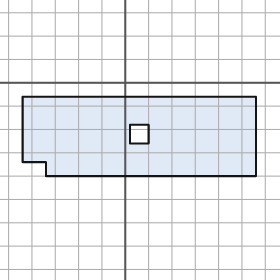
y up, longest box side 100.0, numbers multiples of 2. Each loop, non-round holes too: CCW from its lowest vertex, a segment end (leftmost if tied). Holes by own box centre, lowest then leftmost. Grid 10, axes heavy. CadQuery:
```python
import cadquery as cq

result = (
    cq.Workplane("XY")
    .moveTo(-34.0, -40.0)
    .lineTo(56.0, -40.0)
    .lineTo(56.0, -6.0)
    .lineTo(-44.0, -6.0)
    .lineTo(-44.0, -34.0)
    .lineTo(-34.0, -34.0)
    .close()
    .moveTo(2.0, -26.0)
    .lineTo(10.0, -26.0)
    .lineTo(10.0, -18.0)
    .lineTo(2.0, -18.0)
    .close()
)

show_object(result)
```